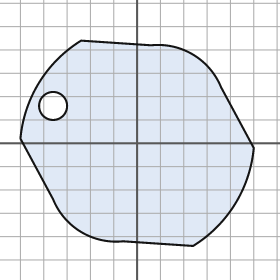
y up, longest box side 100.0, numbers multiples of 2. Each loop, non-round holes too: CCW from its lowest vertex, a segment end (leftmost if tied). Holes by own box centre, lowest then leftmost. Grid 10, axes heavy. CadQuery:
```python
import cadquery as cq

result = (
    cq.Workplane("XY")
    .moveTo(24.0, -44.0)
    .threePointArc((42.0, -26.0), (50.0, -2.0))
    .lineTo(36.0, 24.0)
    .threePointArc((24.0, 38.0), (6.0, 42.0))
    .lineTo(-24.0, 44.0)
    .threePointArc((-42.0, 26.0), (-50.0, 2.0))
    .lineTo(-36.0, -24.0)
    .threePointArc((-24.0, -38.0), (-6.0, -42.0))
    .close()
    .moveTo(-36.0, 16.0)
    .circle(6.0)
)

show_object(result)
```